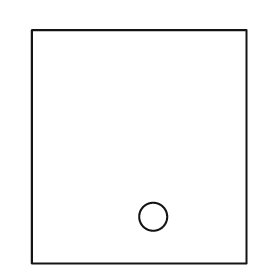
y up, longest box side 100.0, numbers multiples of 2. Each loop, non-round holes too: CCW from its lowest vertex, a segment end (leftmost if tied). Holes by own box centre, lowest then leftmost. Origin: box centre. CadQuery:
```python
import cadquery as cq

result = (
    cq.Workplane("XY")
    .moveTo(-46.0, -50.0)
    .lineTo(46.0, -50.0)
    .lineTo(46.0, 50.0)
    .lineTo(-46.0, 50.0)
    .close()
    .moveTo(6.0, -30.0)
    .circle(6.0)
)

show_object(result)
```